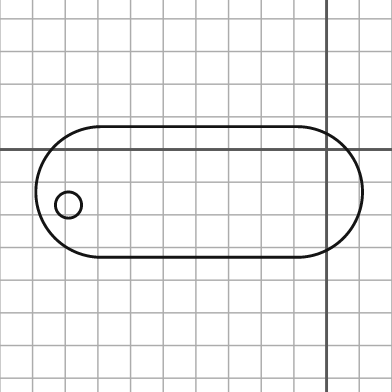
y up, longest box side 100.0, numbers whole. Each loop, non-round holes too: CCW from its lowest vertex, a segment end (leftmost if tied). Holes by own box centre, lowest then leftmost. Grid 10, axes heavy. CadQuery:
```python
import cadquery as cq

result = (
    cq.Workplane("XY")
    .moveTo(-69.0, -33.0)
    .lineTo(-9.0, -33.0)
    .threePointArc((11.0, -13.0), (-9.0, 7.0))
    .lineTo(-69.0, 7.0)
    .threePointArc((-89.0, -13.0), (-69.0, -33.0))
    .close()
    .moveTo(-79.0, -17.0)
    .circle(4.0)
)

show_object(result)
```